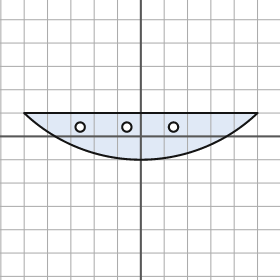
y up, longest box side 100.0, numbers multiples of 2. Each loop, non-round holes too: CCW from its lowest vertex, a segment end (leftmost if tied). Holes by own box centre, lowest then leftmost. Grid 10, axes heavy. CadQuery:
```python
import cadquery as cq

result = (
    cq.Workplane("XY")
    .moveTo(-50.0, 10.0)
    .threePointArc((0.0, -10.0), (50.0, 10.0))
    .close()
    .moveTo(-26.0, 4.0)
    .circle(2.0)
    .moveTo(-6.0, 4.0)
    .circle(2.0)
    .moveTo(14.0, 4.0)
    .circle(2.0)
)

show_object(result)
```